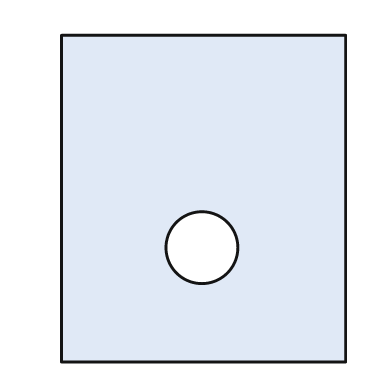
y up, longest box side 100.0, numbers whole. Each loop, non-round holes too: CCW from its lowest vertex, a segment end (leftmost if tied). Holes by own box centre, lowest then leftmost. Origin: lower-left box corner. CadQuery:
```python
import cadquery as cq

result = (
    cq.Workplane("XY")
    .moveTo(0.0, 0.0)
    .lineTo(87.0, 0.0)
    .lineTo(87.0, 100.0)
    .lineTo(0.0, 100.0)
    .close()
    .moveTo(43.0, 35.0)
    .circle(11.0)
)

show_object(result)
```